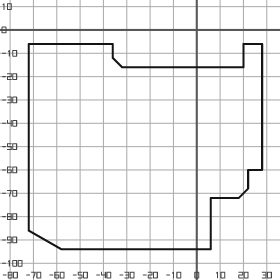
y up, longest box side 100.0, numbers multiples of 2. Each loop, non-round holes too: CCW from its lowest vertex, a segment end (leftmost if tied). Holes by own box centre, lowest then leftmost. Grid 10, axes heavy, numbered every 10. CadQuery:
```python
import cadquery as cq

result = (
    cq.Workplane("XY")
    .moveTo(-58.0, -94.0)
    .lineTo(6.0, -94.0)
    .lineTo(6.0, -72.0)
    .lineTo(18.0, -72.0)
    .lineTo(22.0, -68.0)
    .lineTo(22.0, -60.0)
    .lineTo(28.0, -60.0)
    .lineTo(28.0, -6.0)
    .lineTo(20.0, -6.0)
    .lineTo(20.0, -16.0)
    .lineTo(-32.0, -16.0)
    .lineTo(-36.0, -12.0)
    .lineTo(-36.0, -6.0)
    .lineTo(-72.0, -6.0)
    .lineTo(-72.0, -86.0)
    .close()
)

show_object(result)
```